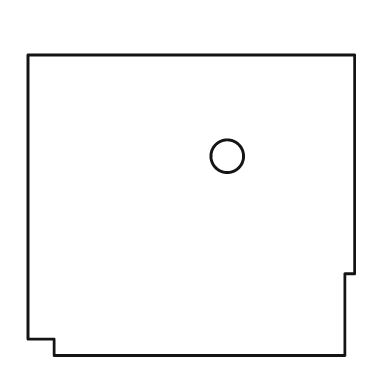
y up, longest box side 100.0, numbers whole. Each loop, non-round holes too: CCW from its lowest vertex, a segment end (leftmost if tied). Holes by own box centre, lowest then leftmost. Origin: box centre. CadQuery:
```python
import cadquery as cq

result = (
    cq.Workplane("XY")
    .moveTo(-42.0, -46.0)
    .lineTo(47.0, -46.0)
    .lineTo(47.0, -21.0)
    .lineTo(50.0, -21.0)
    .lineTo(50.0, 46.0)
    .lineTo(-50.0, 46.0)
    .lineTo(-50.0, -41.0)
    .lineTo(-42.0, -41.0)
    .close()
    .moveTo(11.0, 15.0)
    .circle(5.0)
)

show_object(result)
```